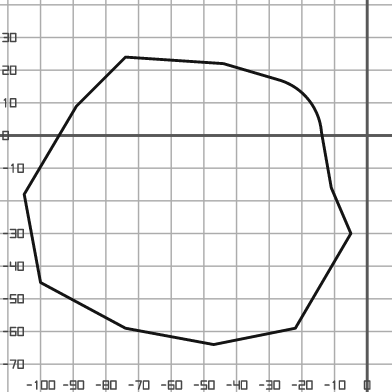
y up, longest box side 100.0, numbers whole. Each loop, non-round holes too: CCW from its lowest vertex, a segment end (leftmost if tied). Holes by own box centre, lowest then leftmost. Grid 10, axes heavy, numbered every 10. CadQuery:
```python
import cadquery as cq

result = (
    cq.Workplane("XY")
    .moveTo(-47.0, -64.0)
    .lineTo(-22.0, -59.0)
    .lineTo(-5.0, -30.0)
    .lineTo(-11.0, -16.0)
    .lineTo(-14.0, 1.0)
    .threePointArc((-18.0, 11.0), (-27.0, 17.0))
    .lineTo(-44.0, 22.0)
    .lineTo(-74.0, 24.0)
    .lineTo(-89.0, 9.0)
    .lineTo(-105.0, -18.0)
    .lineTo(-100.0, -45.0)
    .lineTo(-74.0, -59.0)
    .close()
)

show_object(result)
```